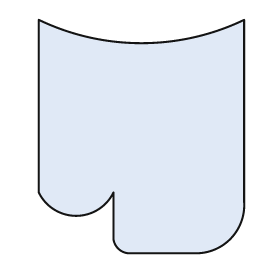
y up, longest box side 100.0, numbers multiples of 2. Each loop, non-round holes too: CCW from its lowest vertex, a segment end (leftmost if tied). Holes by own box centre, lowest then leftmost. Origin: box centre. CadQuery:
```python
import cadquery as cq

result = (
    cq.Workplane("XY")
    .moveTo(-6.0, -50.0)
    .lineTo(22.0, -50.0)
    .threePointArc((38.0, -44.0), (44.0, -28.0))
    .lineTo(44.0, 50.0)
    .threePointArc((0.0, 40.0), (-44.0, 50.0))
    .lineTo(-44.0, -24.0)
    .threePointArc((-28.0, -34.0), (-12.0, -24.0))
    .lineTo(-12.0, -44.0)
    .threePointArc((-10.0, -48.0), (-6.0, -50.0))
    .close()
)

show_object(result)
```